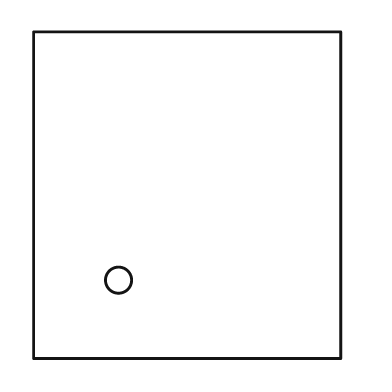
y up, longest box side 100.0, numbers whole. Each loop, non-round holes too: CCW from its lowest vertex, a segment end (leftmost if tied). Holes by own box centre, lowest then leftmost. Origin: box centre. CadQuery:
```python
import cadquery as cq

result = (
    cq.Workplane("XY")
    .moveTo(-47.0, -50.0)
    .lineTo(47.0, -50.0)
    .lineTo(47.0, 50.0)
    .lineTo(-47.0, 50.0)
    .close()
    .moveTo(-21.0, -26.0)
    .circle(4.0)
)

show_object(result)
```